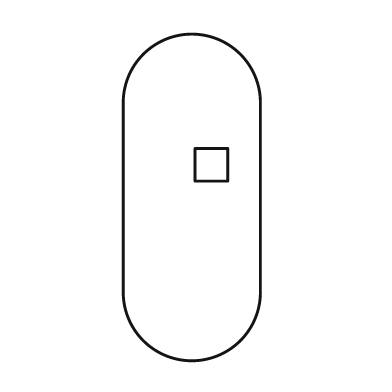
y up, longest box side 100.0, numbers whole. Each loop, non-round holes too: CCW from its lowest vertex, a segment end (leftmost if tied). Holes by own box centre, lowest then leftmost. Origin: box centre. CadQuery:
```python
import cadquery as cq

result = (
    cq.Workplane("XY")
    .moveTo(-21.0, -29.0)
    .threePointArc((0.0, -50.0), (21.0, -29.0))
    .lineTo(21.0, 29.0)
    .threePointArc((0.0, 50.0), (-21.0, 29.0))
    .close()
    .moveTo(1.0, 5.0)
    .lineTo(11.0, 5.0)
    .lineTo(11.0, 15.0)
    .lineTo(1.0, 15.0)
    .close()
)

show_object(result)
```